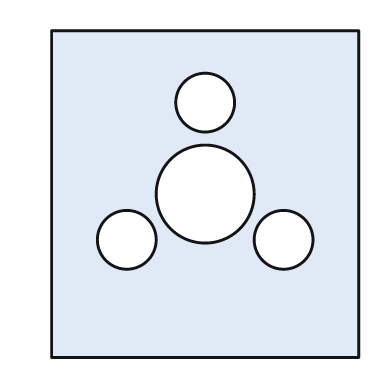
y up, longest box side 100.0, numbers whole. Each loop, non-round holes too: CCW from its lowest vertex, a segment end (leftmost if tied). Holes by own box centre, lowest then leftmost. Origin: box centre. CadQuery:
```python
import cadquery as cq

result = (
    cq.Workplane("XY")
    .moveTo(-47.0, -50.0)
    .lineTo(47.0, -50.0)
    .lineTo(47.0, 50.0)
    .lineTo(-47.0, 50.0)
    .close()
    .moveTo(-24.0, -14.0)
    .circle(9.0)
    .moveTo(24.0, -14.0)
    .circle(9.0)
    .moveTo(0.0, 0.0)
    .circle(15.0)
    .moveTo(0.0, 28.0)
    .circle(9.0)
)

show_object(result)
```